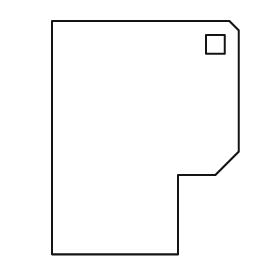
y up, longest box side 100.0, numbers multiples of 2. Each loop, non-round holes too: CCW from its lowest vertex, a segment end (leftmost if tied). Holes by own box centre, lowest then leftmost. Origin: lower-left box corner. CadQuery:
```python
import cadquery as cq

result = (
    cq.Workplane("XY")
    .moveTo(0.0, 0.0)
    .lineTo(54.0, 0.0)
    .lineTo(54.0, 34.0)
    .lineTo(70.0, 34.0)
    .lineTo(80.0, 44.0)
    .lineTo(80.0, 96.0)
    .lineTo(76.0, 100.0)
    .lineTo(0.0, 100.0)
    .close()
    .moveTo(66.0, 86.0)
    .lineTo(74.0, 86.0)
    .lineTo(74.0, 94.0)
    .lineTo(66.0, 94.0)
    .close()
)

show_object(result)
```